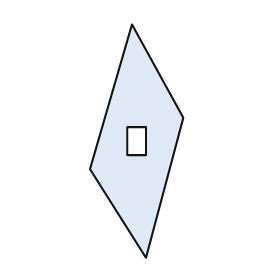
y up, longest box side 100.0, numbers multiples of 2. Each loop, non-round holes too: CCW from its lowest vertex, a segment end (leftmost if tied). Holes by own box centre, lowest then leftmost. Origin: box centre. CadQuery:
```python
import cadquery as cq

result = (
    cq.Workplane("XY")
    .moveTo(4.0, -50.0)
    .lineTo(20.0, 10.0)
    .lineTo(-2.0, 50.0)
    .lineTo(-20.0, -12.0)
    .close()
    .moveTo(-4.0, -6.0)
    .lineTo(4.0, -6.0)
    .lineTo(4.0, 6.0)
    .lineTo(-4.0, 6.0)
    .close()
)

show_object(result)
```